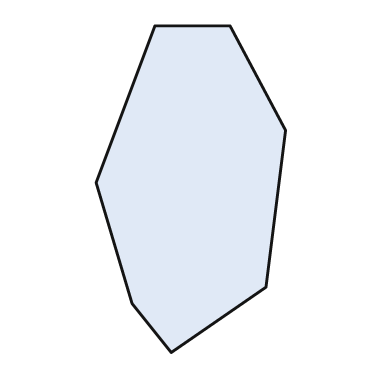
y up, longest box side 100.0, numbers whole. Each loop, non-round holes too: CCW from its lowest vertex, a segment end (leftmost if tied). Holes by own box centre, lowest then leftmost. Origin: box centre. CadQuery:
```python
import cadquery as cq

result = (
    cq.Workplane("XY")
    .moveTo(-6.0, -50.0)
    .lineTo(23.0, -30.0)
    .lineTo(29.0, 18.0)
    .lineTo(12.0, 50.0)
    .lineTo(-11.0, 50.0)
    .lineTo(-29.0, 2.0)
    .lineTo(-18.0, -35.0)
    .close()
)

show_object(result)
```